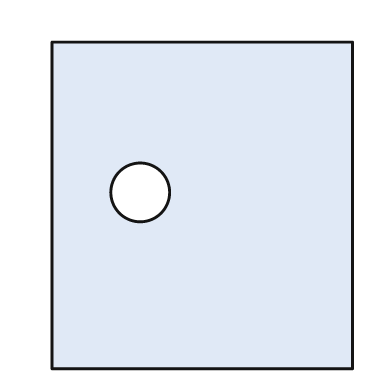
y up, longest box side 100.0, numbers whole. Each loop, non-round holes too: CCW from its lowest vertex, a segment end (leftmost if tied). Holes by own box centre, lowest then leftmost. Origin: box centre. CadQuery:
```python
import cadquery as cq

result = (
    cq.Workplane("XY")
    .moveTo(-46.0, -50.0)
    .lineTo(46.0, -50.0)
    .lineTo(46.0, 50.0)
    .lineTo(-46.0, 50.0)
    .close()
    .moveTo(-19.0, 4.0)
    .circle(9.0)
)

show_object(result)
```